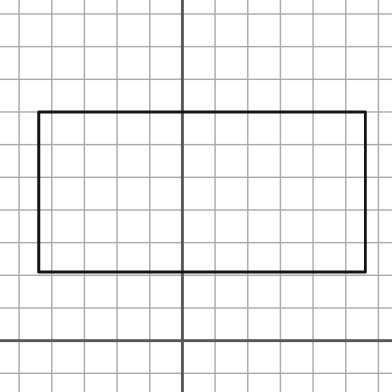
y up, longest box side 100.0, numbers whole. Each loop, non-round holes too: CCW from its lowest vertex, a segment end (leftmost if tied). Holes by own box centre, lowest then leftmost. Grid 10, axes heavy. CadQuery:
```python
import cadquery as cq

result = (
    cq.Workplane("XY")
    .moveTo(-44.0, 21.0)
    .lineTo(56.0, 21.0)
    .lineTo(56.0, 70.0)
    .lineTo(-44.0, 70.0)
    .close()
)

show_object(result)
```